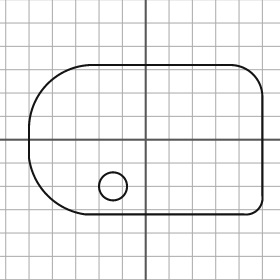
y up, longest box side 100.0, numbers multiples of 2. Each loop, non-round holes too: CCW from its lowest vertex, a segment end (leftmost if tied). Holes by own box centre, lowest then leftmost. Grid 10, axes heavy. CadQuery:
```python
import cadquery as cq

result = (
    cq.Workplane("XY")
    .moveTo(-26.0, -32.0)
    .lineTo(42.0, -32.0)
    .threePointArc((48.0, -30.0), (50.0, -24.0))
    .lineTo(50.0, 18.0)
    .threePointArc((46.0, 28.0), (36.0, 32.0))
    .lineTo(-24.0, 32.0)
    .threePointArc((-42.0, 24.0), (-50.0, 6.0))
    .lineTo(-50.0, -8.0)
    .threePointArc((-42.0, -24.0), (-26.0, -32.0))
    .close()
    .moveTo(-14.0, -20.0)
    .circle(6.0)
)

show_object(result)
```